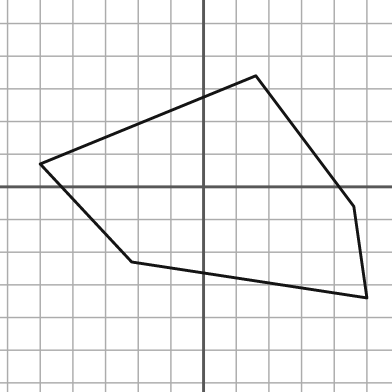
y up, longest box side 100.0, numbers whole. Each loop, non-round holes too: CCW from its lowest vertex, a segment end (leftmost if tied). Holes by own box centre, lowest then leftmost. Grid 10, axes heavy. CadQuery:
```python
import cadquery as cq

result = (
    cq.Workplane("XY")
    .moveTo(50.0, -34.0)
    .lineTo(46.0, -6.0)
    .lineTo(16.0, 34.0)
    .lineTo(-50.0, 7.0)
    .lineTo(-22.0, -23.0)
    .close()
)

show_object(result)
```